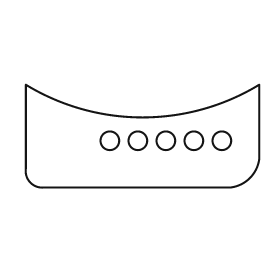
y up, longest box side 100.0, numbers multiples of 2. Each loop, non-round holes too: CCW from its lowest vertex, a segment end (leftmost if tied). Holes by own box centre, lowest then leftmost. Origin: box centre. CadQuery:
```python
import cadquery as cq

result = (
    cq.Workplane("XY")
    .moveTo(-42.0, -22.0)
    .lineTo(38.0, -22.0)
    .threePointArc((46.0, -18.0), (50.0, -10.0))
    .lineTo(50.0, 22.0)
    .threePointArc((0.0, 8.0), (-50.0, 22.0))
    .lineTo(-50.0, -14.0)
    .threePointArc((-48.0, -20.0), (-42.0, -22.0))
    .close()
    .moveTo(-14.0, -2.0)
    .circle(4.0)
    .moveTo(-2.0, -2.0)
    .circle(4.0)
    .moveTo(10.0, -2.0)
    .circle(4.0)
    .moveTo(22.0, -2.0)
    .circle(4.0)
    .moveTo(34.0, -2.0)
    .circle(4.0)
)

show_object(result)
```